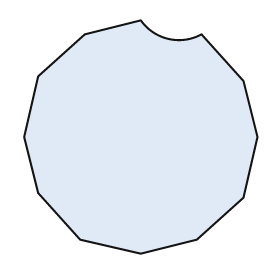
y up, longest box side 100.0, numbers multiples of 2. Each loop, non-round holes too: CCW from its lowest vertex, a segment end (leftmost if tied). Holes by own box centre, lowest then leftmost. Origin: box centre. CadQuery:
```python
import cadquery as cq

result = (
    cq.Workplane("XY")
    .moveTo(0.0, -50.0)
    .lineTo(24.0, -44.0)
    .lineTo(44.0, -26.0)
    .lineTo(50.0, 0.0)
    .lineTo(44.0, 24.0)
    .lineTo(26.0, 44.0)
    .threePointArc((12.0, 42.0), (0.0, 50.0))
    .lineTo(-24.0, 44.0)
    .lineTo(-44.0, 26.0)
    .lineTo(-50.0, 0.0)
    .lineTo(-44.0, -24.0)
    .lineTo(-26.0, -44.0)
    .close()
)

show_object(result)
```